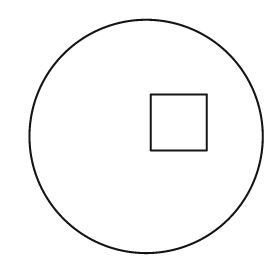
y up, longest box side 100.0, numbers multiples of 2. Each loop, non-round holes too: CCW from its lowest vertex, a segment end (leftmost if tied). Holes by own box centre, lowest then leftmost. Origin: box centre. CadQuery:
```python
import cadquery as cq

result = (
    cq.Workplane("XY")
    .moveTo(0.0, 0.0)
    .circle(50.0)
    .moveTo(2.0, -6.0)
    .lineTo(26.0, -6.0)
    .lineTo(26.0, 18.0)
    .lineTo(2.0, 18.0)
    .close()
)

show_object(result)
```